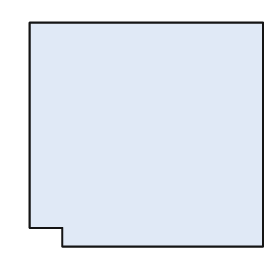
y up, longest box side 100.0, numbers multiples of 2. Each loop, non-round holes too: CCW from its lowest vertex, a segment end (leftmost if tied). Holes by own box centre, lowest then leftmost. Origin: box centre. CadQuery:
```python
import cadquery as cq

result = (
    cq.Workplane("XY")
    .moveTo(-36.0, -48.0)
    .lineTo(50.0, -48.0)
    .lineTo(50.0, 48.0)
    .lineTo(-50.0, 48.0)
    .lineTo(-50.0, -40.0)
    .lineTo(-36.0, -40.0)
    .close()
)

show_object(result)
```